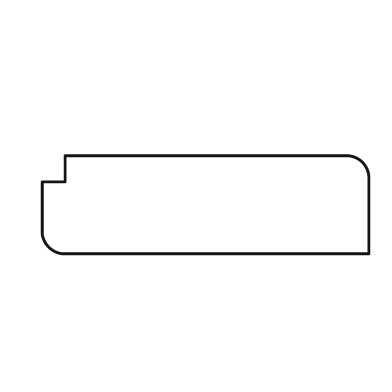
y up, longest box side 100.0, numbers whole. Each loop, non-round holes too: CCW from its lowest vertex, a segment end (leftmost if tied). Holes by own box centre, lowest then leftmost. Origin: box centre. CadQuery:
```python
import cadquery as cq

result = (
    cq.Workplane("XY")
    .moveTo(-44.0, -15.0)
    .lineTo(50.0, -15.0)
    .lineTo(50.0, 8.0)
    .threePointArc((48.0, 13.0), (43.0, 15.0))
    .lineTo(-43.0, 15.0)
    .lineTo(-43.0, 7.0)
    .lineTo(-50.0, 7.0)
    .lineTo(-50.0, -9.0)
    .threePointArc((-48.0, -13.0), (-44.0, -15.0))
    .close()
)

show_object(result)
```